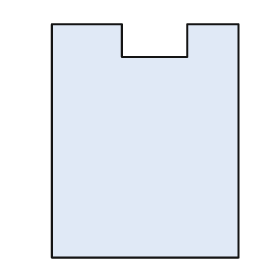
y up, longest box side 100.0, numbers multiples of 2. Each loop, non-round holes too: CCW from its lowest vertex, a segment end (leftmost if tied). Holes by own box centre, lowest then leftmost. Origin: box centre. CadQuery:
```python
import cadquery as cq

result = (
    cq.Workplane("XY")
    .moveTo(-40.0, -50.0)
    .lineTo(40.0, -50.0)
    .lineTo(40.0, 50.0)
    .lineTo(18.0, 50.0)
    .lineTo(18.0, 36.0)
    .lineTo(-10.0, 36.0)
    .lineTo(-10.0, 50.0)
    .lineTo(-40.0, 50.0)
    .close()
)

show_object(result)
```